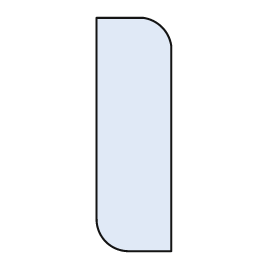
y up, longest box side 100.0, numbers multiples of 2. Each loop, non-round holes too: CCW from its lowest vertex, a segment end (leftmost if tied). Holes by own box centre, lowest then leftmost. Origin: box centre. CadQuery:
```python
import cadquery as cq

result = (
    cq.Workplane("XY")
    .moveTo(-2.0, -50.0)
    .lineTo(16.0, -50.0)
    .lineTo(16.0, 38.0)
    .threePointArc((12.0, 46.0), (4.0, 50.0))
    .lineTo(-16.0, 50.0)
    .lineTo(-16.0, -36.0)
    .threePointArc((-12.0, -46.0), (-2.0, -50.0))
    .close()
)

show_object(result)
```